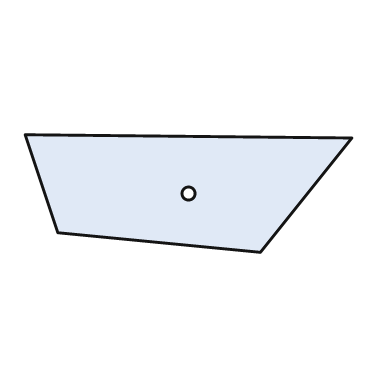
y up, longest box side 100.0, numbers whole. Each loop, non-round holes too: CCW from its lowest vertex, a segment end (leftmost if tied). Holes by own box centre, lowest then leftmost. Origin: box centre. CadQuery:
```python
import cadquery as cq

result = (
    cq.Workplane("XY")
    .moveTo(22.0, -18.0)
    .lineTo(50.0, 17.0)
    .lineTo(-50.0, 18.0)
    .lineTo(-40.0, -12.0)
    .close()
    .moveTo(0.0, 0.0)
    .circle(2.0)
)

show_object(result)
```